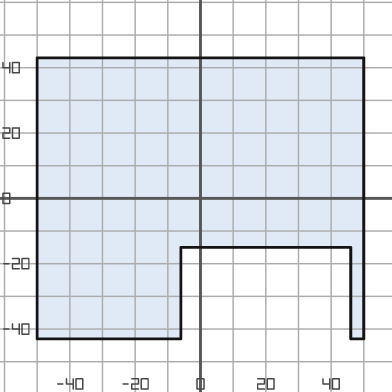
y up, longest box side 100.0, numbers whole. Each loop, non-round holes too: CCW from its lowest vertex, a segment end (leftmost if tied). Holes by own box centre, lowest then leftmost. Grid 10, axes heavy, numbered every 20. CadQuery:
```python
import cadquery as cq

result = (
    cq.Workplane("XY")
    .moveTo(-50.0, -43.0)
    .lineTo(-6.0, -43.0)
    .lineTo(-6.0, -15.0)
    .lineTo(46.0, -15.0)
    .lineTo(46.0, -43.0)
    .lineTo(50.0, -43.0)
    .lineTo(50.0, 43.0)
    .lineTo(-50.0, 43.0)
    .close()
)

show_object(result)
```